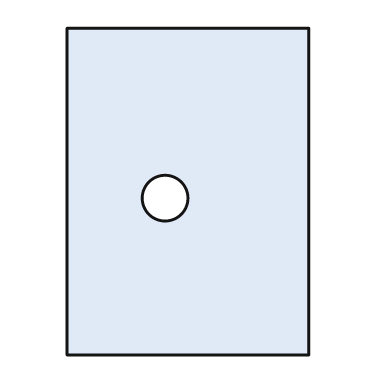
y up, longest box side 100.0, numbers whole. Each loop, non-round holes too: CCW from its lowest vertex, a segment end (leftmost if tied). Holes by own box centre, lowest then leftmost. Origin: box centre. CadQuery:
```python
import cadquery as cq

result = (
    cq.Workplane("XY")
    .moveTo(-37.0, -50.0)
    .lineTo(37.0, -50.0)
    .lineTo(37.0, 50.0)
    .lineTo(-37.0, 50.0)
    .close()
    .moveTo(-7.0, -2.0)
    .circle(7.0)
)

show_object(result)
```